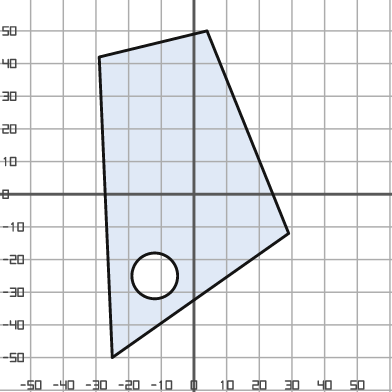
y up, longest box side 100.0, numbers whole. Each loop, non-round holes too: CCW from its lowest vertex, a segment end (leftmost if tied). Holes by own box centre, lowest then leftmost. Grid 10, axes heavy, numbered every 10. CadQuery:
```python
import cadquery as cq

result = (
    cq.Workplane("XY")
    .moveTo(-25.0, -50.0)
    .lineTo(29.0, -12.0)
    .lineTo(4.0, 50.0)
    .lineTo(-29.0, 42.0)
    .close()
    .moveTo(-12.0, -25.0)
    .circle(7.0)
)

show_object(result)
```